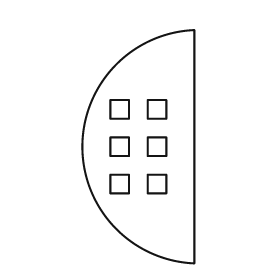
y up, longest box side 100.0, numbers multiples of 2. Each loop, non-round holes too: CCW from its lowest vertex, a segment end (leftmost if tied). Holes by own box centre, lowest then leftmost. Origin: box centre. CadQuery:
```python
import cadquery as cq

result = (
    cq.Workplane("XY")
    .moveTo(24.0, -50.0)
    .lineTo(24.0, 50.0)
    .threePointArc((-24.0, 0.0), (24.0, -50.0))
    .close()
    .moveTo(-12.0, -20.0)
    .lineTo(-4.0, -20.0)
    .lineTo(-4.0, -12.0)
    .lineTo(-12.0, -12.0)
    .close()
    .moveTo(4.0, -20.0)
    .lineTo(12.0, -20.0)
    .lineTo(12.0, -12.0)
    .lineTo(4.0, -12.0)
    .close()
    .moveTo(-12.0, -4.0)
    .lineTo(-4.0, -4.0)
    .lineTo(-4.0, 4.0)
    .lineTo(-12.0, 4.0)
    .close()
    .moveTo(4.0, -4.0)
    .lineTo(12.0, -4.0)
    .lineTo(12.0, 4.0)
    .lineTo(4.0, 4.0)
    .close()
    .moveTo(-12.0, 12.0)
    .lineTo(-4.0, 12.0)
    .lineTo(-4.0, 20.0)
    .lineTo(-12.0, 20.0)
    .close()
    .moveTo(4.0, 12.0)
    .lineTo(12.0, 12.0)
    .lineTo(12.0, 20.0)
    .lineTo(4.0, 20.0)
    .close()
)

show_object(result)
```